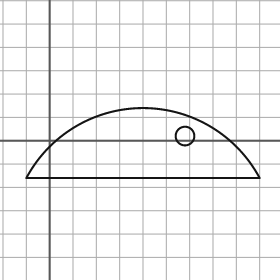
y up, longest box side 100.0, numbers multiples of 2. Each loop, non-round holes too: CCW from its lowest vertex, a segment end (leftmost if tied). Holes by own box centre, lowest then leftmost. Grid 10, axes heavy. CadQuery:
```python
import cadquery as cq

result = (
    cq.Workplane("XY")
    .moveTo(-10.0, -16.0)
    .lineTo(90.0, -16.0)
    .threePointArc((40.0, 14.0), (-10.0, -16.0))
    .close()
    .moveTo(58.0, 2.0)
    .circle(4.0)
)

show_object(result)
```